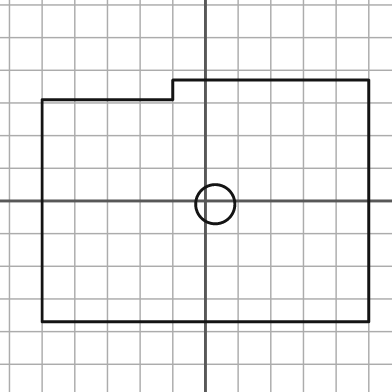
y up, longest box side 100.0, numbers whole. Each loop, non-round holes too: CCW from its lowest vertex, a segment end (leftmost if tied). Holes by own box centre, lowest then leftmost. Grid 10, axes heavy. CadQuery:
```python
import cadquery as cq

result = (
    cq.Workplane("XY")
    .moveTo(-50.0, -37.0)
    .lineTo(50.0, -37.0)
    .lineTo(50.0, 37.0)
    .lineTo(-10.0, 37.0)
    .lineTo(-10.0, 31.0)
    .lineTo(-50.0, 31.0)
    .close()
    .moveTo(3.0, -1.0)
    .circle(6.0)
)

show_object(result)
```